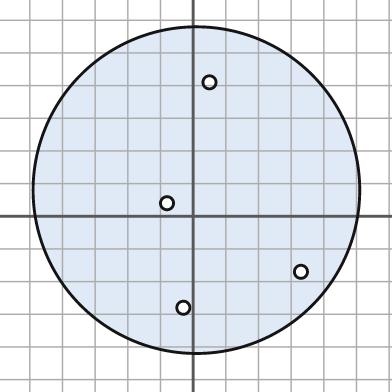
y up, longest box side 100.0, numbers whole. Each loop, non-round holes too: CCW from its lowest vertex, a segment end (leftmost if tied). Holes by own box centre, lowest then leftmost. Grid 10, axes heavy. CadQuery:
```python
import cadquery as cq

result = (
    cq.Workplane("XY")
    .moveTo(1.0, 8.0)
    .circle(50.0)
    .moveTo(-3.0, -28.0)
    .circle(2.0)
    .moveTo(33.0, -17.0)
    .circle(2.0)
    .moveTo(-8.0, 4.0)
    .circle(2.0)
    .moveTo(5.0, 41.0)
    .circle(2.0)
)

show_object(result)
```